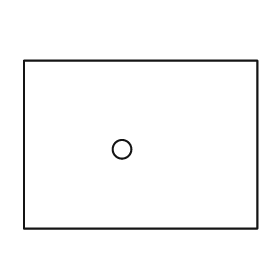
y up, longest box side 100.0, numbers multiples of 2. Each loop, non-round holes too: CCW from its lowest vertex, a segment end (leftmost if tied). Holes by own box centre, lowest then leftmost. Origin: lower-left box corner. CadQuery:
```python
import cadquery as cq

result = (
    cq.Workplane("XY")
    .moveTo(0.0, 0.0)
    .lineTo(100.0, 0.0)
    .lineTo(100.0, 72.0)
    .lineTo(0.0, 72.0)
    .close()
    .moveTo(42.0, 34.0)
    .circle(4.0)
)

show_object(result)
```